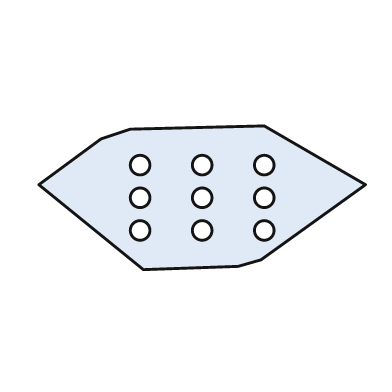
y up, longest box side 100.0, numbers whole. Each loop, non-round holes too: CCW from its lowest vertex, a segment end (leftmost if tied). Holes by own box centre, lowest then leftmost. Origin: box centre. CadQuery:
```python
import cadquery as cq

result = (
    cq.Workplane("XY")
    .moveTo(-18.0, -22.0)
    .lineTo(11.0, -21.0)
    .lineTo(18.0, -19.0)
    .lineTo(50.0, 4.0)
    .lineTo(19.0, 22.0)
    .lineTo(-22.0, 21.0)
    .lineTo(-31.0, 18.0)
    .lineTo(-50.0, 4.0)
    .close()
    .moveTo(-19.0, -10.0)
    .circle(3.0)
    .moveTo(0.0, -10.0)
    .circle(3.0)
    .moveTo(19.0, -10.0)
    .circle(3.0)
    .moveTo(-19.0, 0.0)
    .circle(3.0)
    .moveTo(0.0, 0.0)
    .circle(3.0)
    .moveTo(19.0, 0.0)
    .circle(3.0)
    .moveTo(-19.0, 10.0)
    .circle(3.0)
    .moveTo(0.0, 10.0)
    .circle(3.0)
    .moveTo(19.0, 10.0)
    .circle(3.0)
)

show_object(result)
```